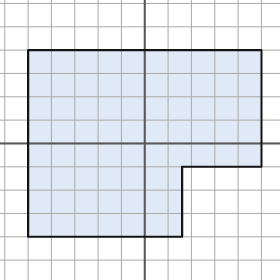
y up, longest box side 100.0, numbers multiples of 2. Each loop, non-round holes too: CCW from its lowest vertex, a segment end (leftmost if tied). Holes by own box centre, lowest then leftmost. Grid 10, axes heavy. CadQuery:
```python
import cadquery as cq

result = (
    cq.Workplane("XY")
    .moveTo(-50.0, -40.0)
    .lineTo(16.0, -40.0)
    .lineTo(16.0, -10.0)
    .lineTo(50.0, -10.0)
    .lineTo(50.0, 40.0)
    .lineTo(-50.0, 40.0)
    .close()
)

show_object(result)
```